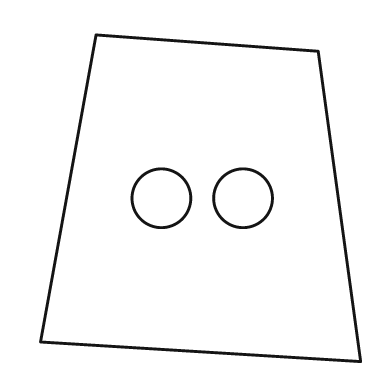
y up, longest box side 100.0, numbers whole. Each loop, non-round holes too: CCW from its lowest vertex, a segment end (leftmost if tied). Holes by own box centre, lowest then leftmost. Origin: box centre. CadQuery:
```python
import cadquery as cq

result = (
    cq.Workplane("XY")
    .moveTo(49.0, -50.0)
    .lineTo(36.0, 45.0)
    .lineTo(-32.0, 50.0)
    .lineTo(-49.0, -44.0)
    .close()
    .moveTo(-12.0, 0.0)
    .circle(9.0)
    .moveTo(13.0, 0.0)
    .circle(9.0)
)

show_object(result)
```